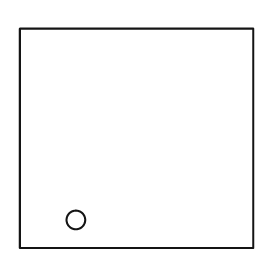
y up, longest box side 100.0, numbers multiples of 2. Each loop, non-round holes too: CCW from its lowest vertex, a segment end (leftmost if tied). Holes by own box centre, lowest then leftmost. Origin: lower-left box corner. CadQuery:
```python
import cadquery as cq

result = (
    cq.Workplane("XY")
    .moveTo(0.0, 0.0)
    .lineTo(100.0, 0.0)
    .lineTo(100.0, 94.0)
    .lineTo(0.0, 94.0)
    .close()
    .moveTo(24.0, 12.0)
    .circle(4.0)
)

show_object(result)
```